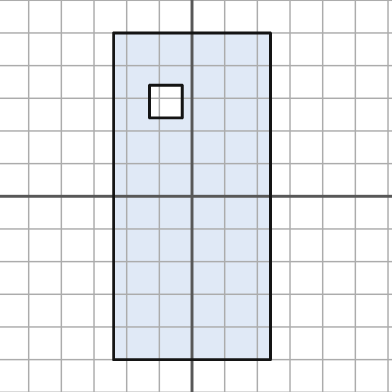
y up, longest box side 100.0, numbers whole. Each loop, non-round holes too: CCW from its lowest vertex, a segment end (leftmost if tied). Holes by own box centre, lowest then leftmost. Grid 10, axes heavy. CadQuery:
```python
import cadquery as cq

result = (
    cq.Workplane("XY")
    .moveTo(-24.0, -50.0)
    .lineTo(24.0, -50.0)
    .lineTo(24.0, 50.0)
    .lineTo(-24.0, 50.0)
    .close()
    .moveTo(-13.0, 24.0)
    .lineTo(-3.0, 24.0)
    .lineTo(-3.0, 34.0)
    .lineTo(-13.0, 34.0)
    .close()
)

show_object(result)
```